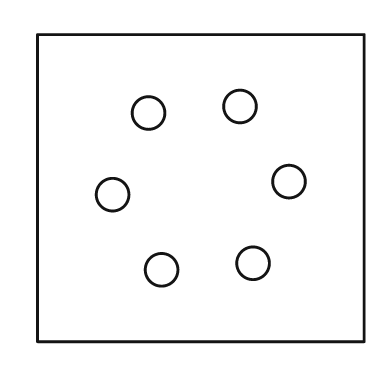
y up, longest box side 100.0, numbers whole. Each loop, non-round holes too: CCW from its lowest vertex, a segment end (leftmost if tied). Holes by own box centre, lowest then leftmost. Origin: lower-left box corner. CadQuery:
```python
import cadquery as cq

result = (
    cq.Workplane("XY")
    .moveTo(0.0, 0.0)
    .lineTo(100.0, 0.0)
    .lineTo(100.0, 94.0)
    .lineTo(0.0, 94.0)
    .close()
    .moveTo(38.0, 22.0)
    .circle(5.0)
    .moveTo(66.0, 24.0)
    .circle(5.0)
    .moveTo(23.0, 45.0)
    .circle(5.0)
    .moveTo(77.0, 49.0)
    .circle(5.0)
    .moveTo(34.0, 70.0)
    .circle(5.0)
    .moveTo(62.0, 72.0)
    .circle(5.0)
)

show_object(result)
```